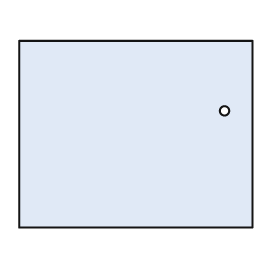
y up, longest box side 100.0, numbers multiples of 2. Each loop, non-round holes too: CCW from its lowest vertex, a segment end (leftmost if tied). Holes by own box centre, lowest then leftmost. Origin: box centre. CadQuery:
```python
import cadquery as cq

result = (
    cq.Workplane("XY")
    .moveTo(-50.0, -40.0)
    .lineTo(50.0, -40.0)
    .lineTo(50.0, 40.0)
    .lineTo(-50.0, 40.0)
    .close()
    .moveTo(38.0, 10.0)
    .circle(2.0)
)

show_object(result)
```